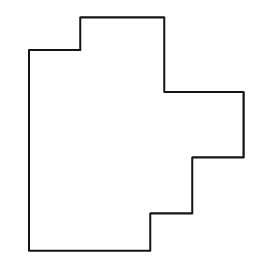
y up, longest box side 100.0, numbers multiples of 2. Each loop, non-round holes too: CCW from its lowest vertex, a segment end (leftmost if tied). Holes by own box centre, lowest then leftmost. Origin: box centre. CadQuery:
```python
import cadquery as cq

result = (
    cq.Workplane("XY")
    .moveTo(-46.0, -50.0)
    .lineTo(6.0, -50.0)
    .lineTo(6.0, -34.0)
    .lineTo(24.0, -34.0)
    .lineTo(24.0, -10.0)
    .lineTo(46.0, -10.0)
    .lineTo(46.0, 18.0)
    .lineTo(12.0, 18.0)
    .lineTo(12.0, 50.0)
    .lineTo(-24.0, 50.0)
    .lineTo(-24.0, 36.0)
    .lineTo(-46.0, 36.0)
    .close()
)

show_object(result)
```